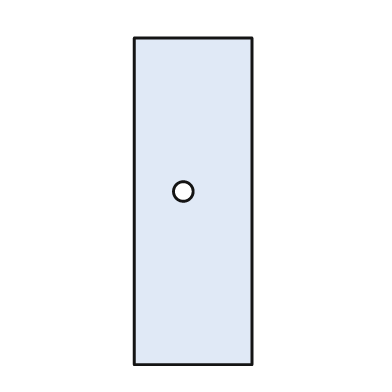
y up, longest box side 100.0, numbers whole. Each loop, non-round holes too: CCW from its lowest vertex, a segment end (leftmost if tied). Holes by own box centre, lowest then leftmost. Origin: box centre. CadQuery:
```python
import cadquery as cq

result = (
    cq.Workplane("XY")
    .moveTo(-18.0, -50.0)
    .lineTo(18.0, -50.0)
    .lineTo(18.0, 50.0)
    .lineTo(-18.0, 50.0)
    .close()
    .moveTo(-3.0, 3.0)
    .circle(3.0)
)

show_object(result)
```